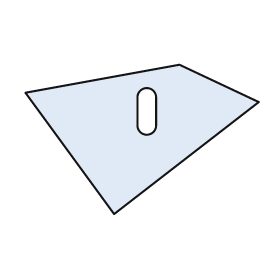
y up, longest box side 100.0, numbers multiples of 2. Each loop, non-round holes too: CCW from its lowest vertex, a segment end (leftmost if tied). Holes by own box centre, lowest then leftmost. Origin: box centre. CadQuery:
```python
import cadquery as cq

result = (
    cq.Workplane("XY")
    .moveTo(-12.0, -32.0)
    .lineTo(50.0, 16.0)
    .lineTo(16.0, 32.0)
    .lineTo(-50.0, 20.0)
    .close()
    .moveTo(-2.0, 6.0)
    .threePointArc((2.0, 2.0), (6.0, 6.0))
    .lineTo(6.0, 18.0)
    .threePointArc((2.0, 22.0), (-2.0, 18.0))
    .close()
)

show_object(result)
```